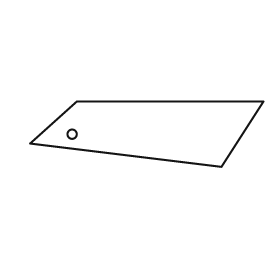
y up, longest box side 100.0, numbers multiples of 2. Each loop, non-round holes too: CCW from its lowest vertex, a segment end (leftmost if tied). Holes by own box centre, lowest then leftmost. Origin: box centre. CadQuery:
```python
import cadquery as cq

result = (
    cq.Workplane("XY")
    .moveTo(32.0, -14.0)
    .lineTo(50.0, 14.0)
    .lineTo(-30.0, 14.0)
    .lineTo(-50.0, -4.0)
    .close()
    .moveTo(-32.0, 0.0)
    .circle(2.0)
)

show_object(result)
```